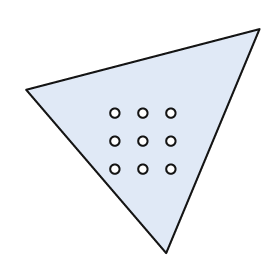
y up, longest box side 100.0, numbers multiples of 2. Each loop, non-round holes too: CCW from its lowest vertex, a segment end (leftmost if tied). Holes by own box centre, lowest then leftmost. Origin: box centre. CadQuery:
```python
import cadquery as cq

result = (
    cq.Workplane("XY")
    .moveTo(10.0, -48.0)
    .lineTo(50.0, 48.0)
    .lineTo(-50.0, 22.0)
    .close()
    .moveTo(-12.0, -12.0)
    .circle(2.0)
    .moveTo(0.0, -12.0)
    .circle(2.0)
    .moveTo(12.0, -12.0)
    .circle(2.0)
    .moveTo(-12.0, 0.0)
    .circle(2.0)
    .moveTo(0.0, 0.0)
    .circle(2.0)
    .moveTo(12.0, 0.0)
    .circle(2.0)
    .moveTo(-12.0, 12.0)
    .circle(2.0)
    .moveTo(0.0, 12.0)
    .circle(2.0)
    .moveTo(12.0, 12.0)
    .circle(2.0)
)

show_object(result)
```